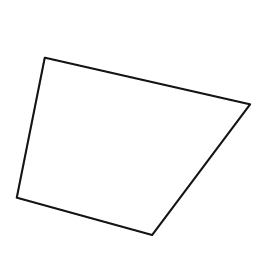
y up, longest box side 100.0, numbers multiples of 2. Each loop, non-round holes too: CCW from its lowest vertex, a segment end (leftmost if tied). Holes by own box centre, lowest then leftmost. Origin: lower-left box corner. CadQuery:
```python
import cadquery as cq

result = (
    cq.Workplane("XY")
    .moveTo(58.0, 0.0)
    .lineTo(100.0, 56.0)
    .lineTo(12.0, 76.0)
    .lineTo(0.0, 16.0)
    .close()
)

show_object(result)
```